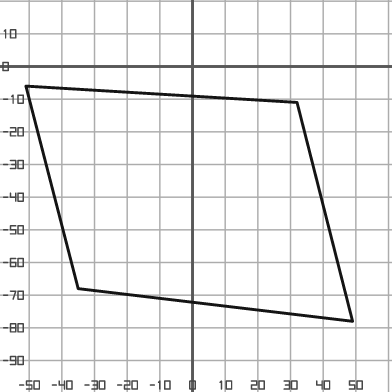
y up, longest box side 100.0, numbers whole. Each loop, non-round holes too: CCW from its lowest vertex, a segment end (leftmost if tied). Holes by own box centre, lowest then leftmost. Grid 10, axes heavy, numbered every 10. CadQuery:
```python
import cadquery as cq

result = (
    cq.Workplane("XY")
    .moveTo(49.0, -78.0)
    .lineTo(32.0, -11.0)
    .lineTo(-51.0, -6.0)
    .lineTo(-35.0, -68.0)
    .close()
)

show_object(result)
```